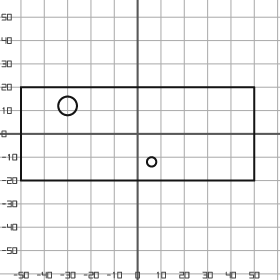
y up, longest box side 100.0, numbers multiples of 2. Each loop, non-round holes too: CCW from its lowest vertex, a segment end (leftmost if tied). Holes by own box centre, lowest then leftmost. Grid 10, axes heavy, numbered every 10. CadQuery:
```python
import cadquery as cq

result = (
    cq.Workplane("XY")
    .moveTo(-50.0, -20.0)
    .lineTo(50.0, -20.0)
    .lineTo(50.0, 20.0)
    .lineTo(-50.0, 20.0)
    .close()
    .moveTo(6.0, -12.0)
    .circle(2.0)
    .moveTo(-30.0, 12.0)
    .circle(4.0)
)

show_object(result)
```